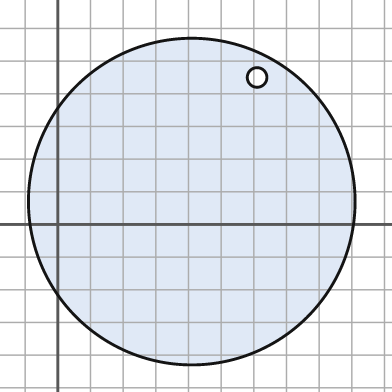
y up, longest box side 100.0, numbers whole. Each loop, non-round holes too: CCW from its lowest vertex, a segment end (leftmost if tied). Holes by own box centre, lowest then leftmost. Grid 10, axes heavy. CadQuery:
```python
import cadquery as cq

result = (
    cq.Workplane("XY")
    .moveTo(41.0, 7.0)
    .circle(50.0)
    .moveTo(61.0, 45.0)
    .circle(3.0)
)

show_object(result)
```